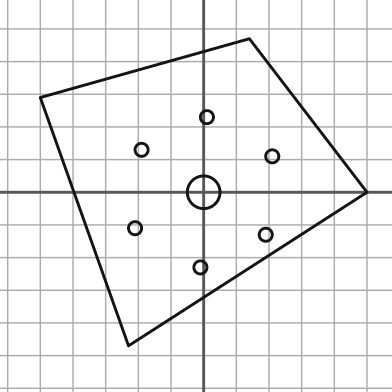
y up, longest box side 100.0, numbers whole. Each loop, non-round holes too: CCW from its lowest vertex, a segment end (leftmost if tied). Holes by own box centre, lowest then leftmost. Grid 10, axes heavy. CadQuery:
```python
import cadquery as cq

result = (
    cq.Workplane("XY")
    .moveTo(-23.0, -47.0)
    .lineTo(50.0, 0.0)
    .lineTo(14.0, 47.0)
    .lineTo(-50.0, 29.0)
    .close()
    .moveTo(-1.0, -23.0)
    .circle(2.0)
    .moveTo(19.0, -13.0)
    .circle(2.0)
    .moveTo(-21.0, -11.0)
    .circle(2.0)
    .moveTo(0.0, 0.0)
    .circle(5.0)
    .moveTo(21.0, 11.0)
    .circle(2.0)
    .moveTo(-19.0, 13.0)
    .circle(2.0)
    .moveTo(1.0, 23.0)
    .circle(2.0)
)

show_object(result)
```